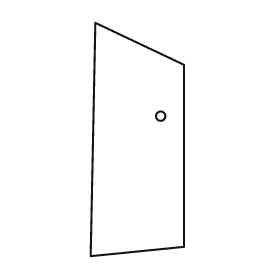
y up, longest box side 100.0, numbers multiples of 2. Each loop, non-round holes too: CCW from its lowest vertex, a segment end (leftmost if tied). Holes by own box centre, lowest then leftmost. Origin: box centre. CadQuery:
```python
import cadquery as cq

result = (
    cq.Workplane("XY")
    .moveTo(-20.0, -50.0)
    .lineTo(20.0, -46.0)
    .lineTo(20.0, 32.0)
    .lineTo(-18.0, 50.0)
    .close()
    .moveTo(10.0, 10.0)
    .circle(2.0)
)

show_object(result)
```